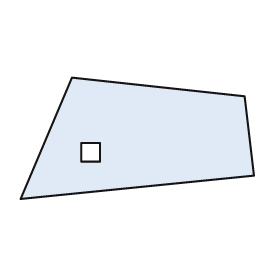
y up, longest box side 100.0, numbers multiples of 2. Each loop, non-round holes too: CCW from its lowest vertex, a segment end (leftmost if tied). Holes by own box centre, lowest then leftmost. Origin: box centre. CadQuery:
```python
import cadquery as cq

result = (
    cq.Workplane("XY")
    .moveTo(-50.0, -26.0)
    .lineTo(50.0, -16.0)
    .lineTo(46.0, 18.0)
    .lineTo(-28.0, 26.0)
    .close()
    .moveTo(-24.0, -10.0)
    .lineTo(-16.0, -10.0)
    .lineTo(-16.0, -2.0)
    .lineTo(-24.0, -2.0)
    .close()
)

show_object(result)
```